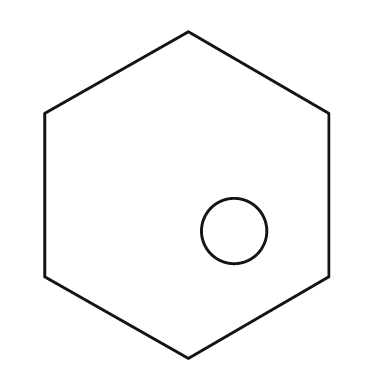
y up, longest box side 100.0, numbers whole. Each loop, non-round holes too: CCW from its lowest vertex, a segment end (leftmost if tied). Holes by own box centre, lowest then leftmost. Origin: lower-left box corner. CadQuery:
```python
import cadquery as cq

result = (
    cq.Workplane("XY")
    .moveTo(44.0, 0.0)
    .lineTo(87.0, 25.0)
    .lineTo(87.0, 75.0)
    .lineTo(44.0, 100.0)
    .lineTo(0.0, 75.0)
    .lineTo(0.0, 25.0)
    .close()
    .moveTo(58.0, 39.0)
    .circle(10.0)
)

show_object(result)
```